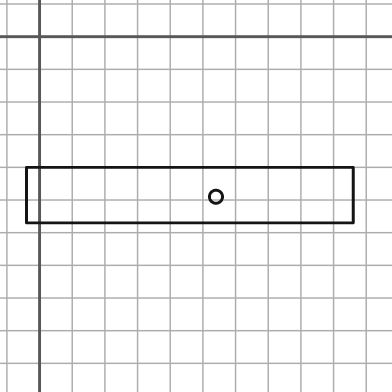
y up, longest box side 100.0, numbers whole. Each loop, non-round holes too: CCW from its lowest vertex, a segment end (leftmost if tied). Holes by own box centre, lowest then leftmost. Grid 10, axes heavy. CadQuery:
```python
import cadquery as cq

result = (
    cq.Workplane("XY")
    .moveTo(-4.0, -57.0)
    .lineTo(96.0, -57.0)
    .lineTo(96.0, -40.0)
    .lineTo(-4.0, -40.0)
    .close()
    .moveTo(54.0, -49.0)
    .circle(2.0)
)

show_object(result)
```